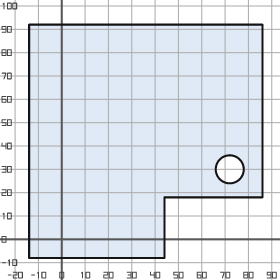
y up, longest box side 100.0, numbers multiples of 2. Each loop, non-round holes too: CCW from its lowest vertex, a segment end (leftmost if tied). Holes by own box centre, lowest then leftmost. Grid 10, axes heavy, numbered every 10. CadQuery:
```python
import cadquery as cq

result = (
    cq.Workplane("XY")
    .moveTo(-14.0, -8.0)
    .lineTo(44.0, -8.0)
    .lineTo(44.0, 18.0)
    .lineTo(86.0, 18.0)
    .lineTo(86.0, 92.0)
    .lineTo(-14.0, 92.0)
    .close()
    .moveTo(72.0, 30.0)
    .circle(6.0)
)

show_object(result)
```